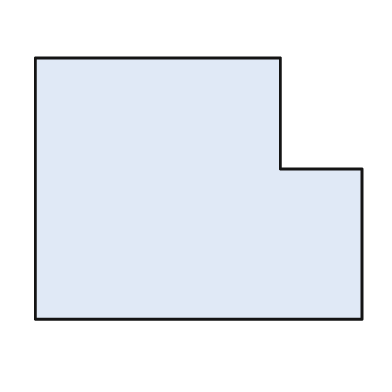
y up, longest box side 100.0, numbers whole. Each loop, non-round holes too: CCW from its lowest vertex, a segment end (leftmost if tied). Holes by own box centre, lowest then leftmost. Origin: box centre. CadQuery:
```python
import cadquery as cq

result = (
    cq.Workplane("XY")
    .moveTo(-50.0, -40.0)
    .lineTo(50.0, -40.0)
    .lineTo(50.0, 6.0)
    .lineTo(25.0, 6.0)
    .lineTo(25.0, 40.0)
    .lineTo(-50.0, 40.0)
    .close()
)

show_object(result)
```